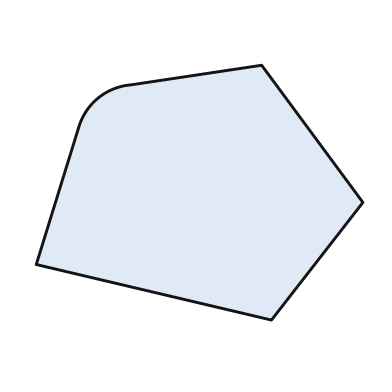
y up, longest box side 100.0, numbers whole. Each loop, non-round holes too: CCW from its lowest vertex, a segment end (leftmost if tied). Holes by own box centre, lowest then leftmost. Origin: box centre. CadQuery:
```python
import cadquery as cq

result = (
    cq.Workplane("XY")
    .moveTo(22.0, -39.0)
    .lineTo(50.0, -3.0)
    .lineTo(19.0, 39.0)
    .lineTo(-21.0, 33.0)
    .threePointArc((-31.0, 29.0), (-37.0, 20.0))
    .lineTo(-50.0, -22.0)
    .close()
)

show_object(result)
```